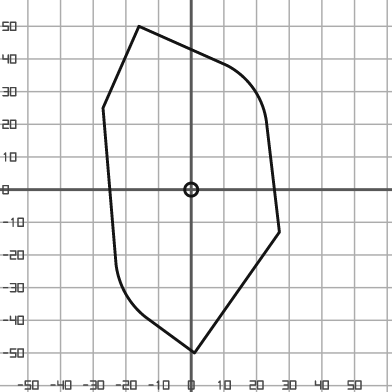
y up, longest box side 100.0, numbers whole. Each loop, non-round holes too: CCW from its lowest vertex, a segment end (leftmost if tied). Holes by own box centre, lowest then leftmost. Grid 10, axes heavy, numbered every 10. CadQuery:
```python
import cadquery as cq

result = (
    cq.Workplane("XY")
    .moveTo(1.0, -50.0)
    .lineTo(27.0, -13.0)
    .lineTo(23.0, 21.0)
    .threePointArc((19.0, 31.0), (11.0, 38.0))
    .lineTo(-16.0, 50.0)
    .lineTo(-27.0, 25.0)
    .lineTo(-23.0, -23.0)
    .threePointArc((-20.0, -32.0), (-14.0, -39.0))
    .close()
    .moveTo(0.0, 0.0)
    .circle(2.0)
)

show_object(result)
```